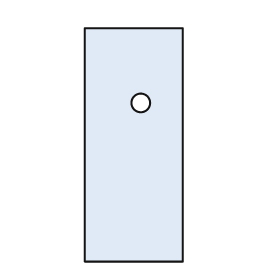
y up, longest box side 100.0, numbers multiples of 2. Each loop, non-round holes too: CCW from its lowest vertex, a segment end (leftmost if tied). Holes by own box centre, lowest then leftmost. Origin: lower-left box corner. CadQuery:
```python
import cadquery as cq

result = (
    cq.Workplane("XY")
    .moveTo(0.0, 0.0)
    .lineTo(42.0, 0.0)
    .lineTo(42.0, 100.0)
    .lineTo(0.0, 100.0)
    .close()
    .moveTo(24.0, 68.0)
    .circle(4.0)
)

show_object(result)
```